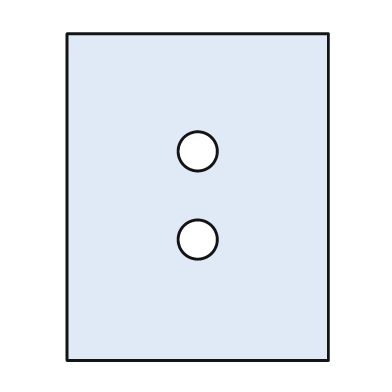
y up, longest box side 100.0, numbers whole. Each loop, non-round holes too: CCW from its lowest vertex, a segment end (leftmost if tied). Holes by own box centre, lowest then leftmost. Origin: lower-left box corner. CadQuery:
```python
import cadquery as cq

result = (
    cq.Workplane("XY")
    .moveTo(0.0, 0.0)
    .lineTo(80.0, 0.0)
    .lineTo(80.0, 100.0)
    .lineTo(0.0, 100.0)
    .close()
    .moveTo(40.0, 37.0)
    .circle(6.0)
    .moveTo(40.0, 64.0)
    .circle(6.0)
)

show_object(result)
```